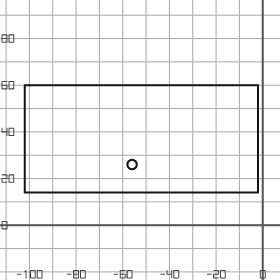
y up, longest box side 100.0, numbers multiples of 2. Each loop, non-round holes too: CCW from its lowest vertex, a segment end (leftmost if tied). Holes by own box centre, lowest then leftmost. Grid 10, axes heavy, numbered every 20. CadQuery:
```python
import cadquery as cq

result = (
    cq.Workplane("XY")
    .moveTo(-102.0, 14.0)
    .lineTo(-2.0, 14.0)
    .lineTo(-2.0, 60.0)
    .lineTo(-102.0, 60.0)
    .close()
    .moveTo(-56.0, 26.0)
    .circle(2.0)
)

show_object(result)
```